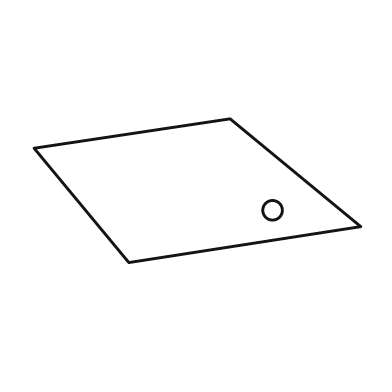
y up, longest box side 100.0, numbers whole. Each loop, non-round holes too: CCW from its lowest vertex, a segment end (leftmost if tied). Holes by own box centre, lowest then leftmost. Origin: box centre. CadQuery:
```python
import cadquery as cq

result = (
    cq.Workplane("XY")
    .moveTo(-21.0, -22.0)
    .lineTo(50.0, -11.0)
    .lineTo(10.0, 22.0)
    .lineTo(-50.0, 13.0)
    .close()
    .moveTo(23.0, -6.0)
    .circle(3.0)
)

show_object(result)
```